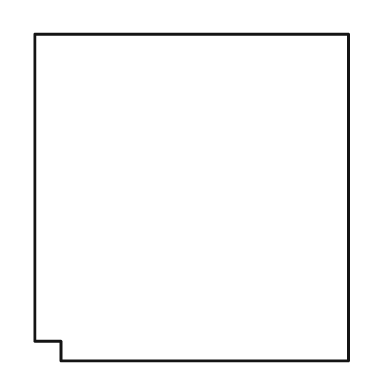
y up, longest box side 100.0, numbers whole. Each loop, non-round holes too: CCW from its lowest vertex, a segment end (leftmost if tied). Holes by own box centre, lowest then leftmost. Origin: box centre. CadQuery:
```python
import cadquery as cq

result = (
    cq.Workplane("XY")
    .moveTo(-40.0, -50.0)
    .lineTo(48.0, -50.0)
    .lineTo(48.0, 50.0)
    .lineTo(-48.0, 50.0)
    .lineTo(-48.0, -44.0)
    .lineTo(-40.0, -44.0)
    .close()
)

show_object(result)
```